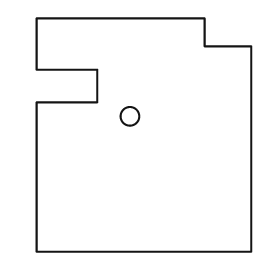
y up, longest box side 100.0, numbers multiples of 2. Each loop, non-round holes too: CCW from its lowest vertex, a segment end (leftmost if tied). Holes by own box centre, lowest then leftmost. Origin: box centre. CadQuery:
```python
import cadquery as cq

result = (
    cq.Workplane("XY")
    .moveTo(-46.0, -50.0)
    .lineTo(46.0, -50.0)
    .lineTo(46.0, 38.0)
    .lineTo(26.0, 38.0)
    .lineTo(26.0, 50.0)
    .lineTo(-46.0, 50.0)
    .lineTo(-46.0, 28.0)
    .lineTo(-20.0, 28.0)
    .lineTo(-20.0, 14.0)
    .lineTo(-46.0, 14.0)
    .close()
    .moveTo(-6.0, 8.0)
    .circle(4.0)
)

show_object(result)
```